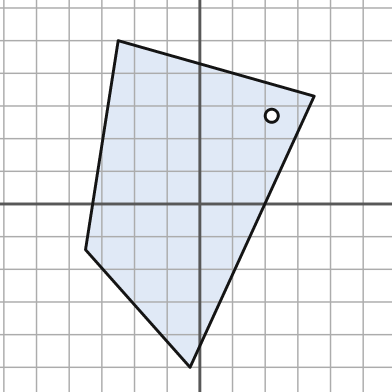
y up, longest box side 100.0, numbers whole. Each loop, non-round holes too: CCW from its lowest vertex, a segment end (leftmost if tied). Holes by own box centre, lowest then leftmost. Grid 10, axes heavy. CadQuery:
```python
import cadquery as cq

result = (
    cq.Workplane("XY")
    .moveTo(-3.0, -50.0)
    .lineTo(35.0, 33.0)
    .lineTo(-25.0, 50.0)
    .lineTo(-35.0, -14.0)
    .close()
    .moveTo(22.0, 27.0)
    .circle(2.0)
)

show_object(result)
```